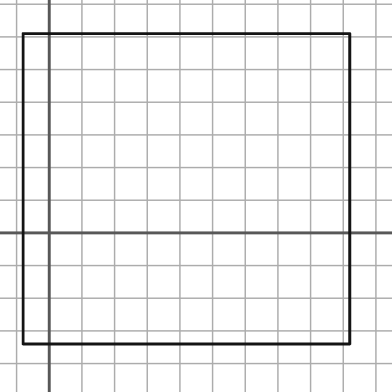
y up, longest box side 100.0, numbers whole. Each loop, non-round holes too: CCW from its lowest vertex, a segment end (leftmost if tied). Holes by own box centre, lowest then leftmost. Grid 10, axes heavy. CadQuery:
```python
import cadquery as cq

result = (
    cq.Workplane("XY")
    .moveTo(-8.0, -34.0)
    .lineTo(92.0, -34.0)
    .lineTo(92.0, 61.0)
    .lineTo(-8.0, 61.0)
    .close()
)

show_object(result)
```